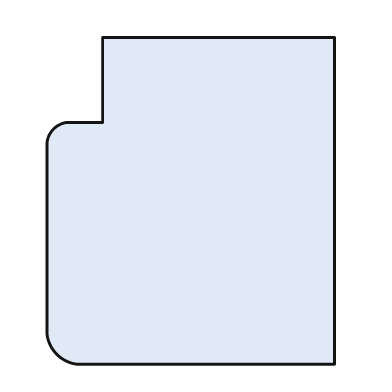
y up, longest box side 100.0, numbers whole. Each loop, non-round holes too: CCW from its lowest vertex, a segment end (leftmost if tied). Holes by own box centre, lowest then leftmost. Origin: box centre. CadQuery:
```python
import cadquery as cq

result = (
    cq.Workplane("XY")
    .moveTo(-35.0, -50.0)
    .lineTo(44.0, -50.0)
    .lineTo(44.0, 50.0)
    .lineTo(-27.0, 50.0)
    .lineTo(-27.0, 24.0)
    .lineTo(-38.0, 24.0)
    .threePointArc((-42.0, 22.0), (-44.0, 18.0))
    .lineTo(-44.0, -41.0)
    .threePointArc((-41.0, -47.0), (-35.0, -50.0))
    .close()
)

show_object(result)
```